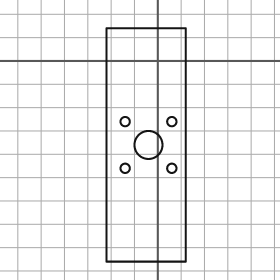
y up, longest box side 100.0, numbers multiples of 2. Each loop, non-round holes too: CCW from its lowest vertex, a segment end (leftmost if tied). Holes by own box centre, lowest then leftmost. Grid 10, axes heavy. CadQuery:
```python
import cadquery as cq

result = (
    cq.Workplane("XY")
    .moveTo(-22.0, -86.0)
    .lineTo(12.0, -86.0)
    .lineTo(12.0, 14.0)
    .lineTo(-22.0, 14.0)
    .close()
    .moveTo(-14.0, -46.0)
    .circle(2.0)
    .moveTo(6.0, -46.0)
    .circle(2.0)
    .moveTo(-4.0, -36.0)
    .circle(6.0)
    .moveTo(-14.0, -26.0)
    .circle(2.0)
    .moveTo(6.0, -26.0)
    .circle(2.0)
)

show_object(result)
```